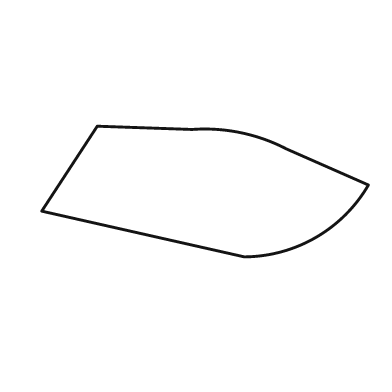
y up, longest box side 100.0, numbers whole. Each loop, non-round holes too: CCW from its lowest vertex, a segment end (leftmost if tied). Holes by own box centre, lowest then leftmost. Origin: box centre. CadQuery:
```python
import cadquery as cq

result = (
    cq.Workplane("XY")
    .moveTo(12.0, -20.0)
    .threePointArc((34.0, -14.0), (50.0, 2.0))
    .lineTo(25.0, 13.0)
    .threePointArc((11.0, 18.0), (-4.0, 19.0))
    .lineTo(-33.0, 20.0)
    .lineTo(-50.0, -6.0)
    .close()
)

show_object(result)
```